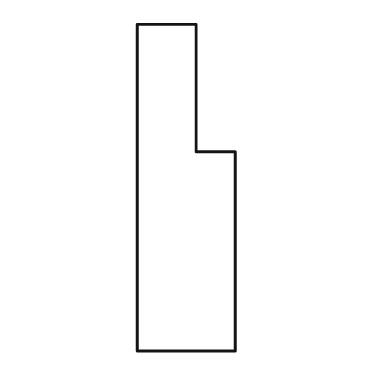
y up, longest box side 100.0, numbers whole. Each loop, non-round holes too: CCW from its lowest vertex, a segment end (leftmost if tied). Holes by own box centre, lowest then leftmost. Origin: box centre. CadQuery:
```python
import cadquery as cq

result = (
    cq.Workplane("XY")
    .moveTo(-15.0, -50.0)
    .lineTo(15.0, -50.0)
    .lineTo(15.0, 11.0)
    .lineTo(3.0, 11.0)
    .lineTo(3.0, 50.0)
    .lineTo(-15.0, 50.0)
    .close()
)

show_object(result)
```